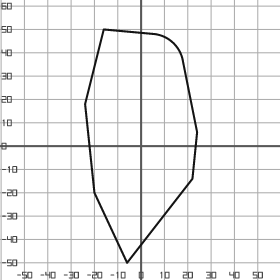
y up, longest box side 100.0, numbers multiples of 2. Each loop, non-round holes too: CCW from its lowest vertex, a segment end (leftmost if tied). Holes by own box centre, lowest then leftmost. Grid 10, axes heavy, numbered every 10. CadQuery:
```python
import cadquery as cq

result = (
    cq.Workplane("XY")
    .moveTo(-6.0, -50.0)
    .lineTo(22.0, -14.0)
    .lineTo(24.0, 6.0)
    .lineTo(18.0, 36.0)
    .threePointArc((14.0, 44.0), (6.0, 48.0))
    .lineTo(-16.0, 50.0)
    .lineTo(-24.0, 18.0)
    .lineTo(-20.0, -20.0)
    .close()
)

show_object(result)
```